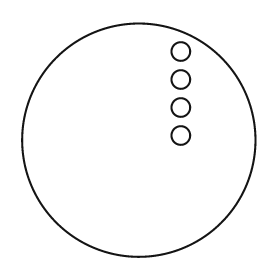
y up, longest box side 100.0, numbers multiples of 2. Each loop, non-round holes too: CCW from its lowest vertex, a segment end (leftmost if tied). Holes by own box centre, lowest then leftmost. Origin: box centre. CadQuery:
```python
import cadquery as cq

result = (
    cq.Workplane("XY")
    .moveTo(0.0, 0.0)
    .circle(50.0)
    .moveTo(18.0, 2.0)
    .circle(4.0)
    .moveTo(18.0, 14.0)
    .circle(4.0)
    .moveTo(18.0, 26.0)
    .circle(4.0)
    .moveTo(18.0, 38.0)
    .circle(4.0)
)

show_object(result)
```